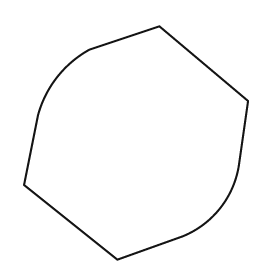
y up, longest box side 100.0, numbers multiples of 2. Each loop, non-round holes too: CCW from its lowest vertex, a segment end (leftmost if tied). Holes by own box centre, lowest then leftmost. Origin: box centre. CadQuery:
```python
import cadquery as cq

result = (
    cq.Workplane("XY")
    .moveTo(-8.0, -50.0)
    .lineTo(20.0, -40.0)
    .threePointArc((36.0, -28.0), (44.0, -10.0))
    .lineTo(48.0, 18.0)
    .lineTo(10.0, 50.0)
    .lineTo(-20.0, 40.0)
    .threePointArc((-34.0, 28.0), (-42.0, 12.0))
    .lineTo(-48.0, -18.0)
    .close()
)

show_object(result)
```